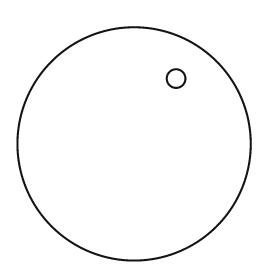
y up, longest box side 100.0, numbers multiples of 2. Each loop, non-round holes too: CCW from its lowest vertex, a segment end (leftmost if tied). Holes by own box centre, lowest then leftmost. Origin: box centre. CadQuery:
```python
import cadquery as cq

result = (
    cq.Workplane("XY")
    .moveTo(0.0, 0.0)
    .circle(50.0)
    .moveTo(18.0, 28.0)
    .circle(4.0)
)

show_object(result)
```